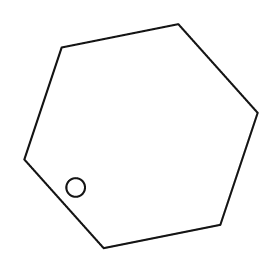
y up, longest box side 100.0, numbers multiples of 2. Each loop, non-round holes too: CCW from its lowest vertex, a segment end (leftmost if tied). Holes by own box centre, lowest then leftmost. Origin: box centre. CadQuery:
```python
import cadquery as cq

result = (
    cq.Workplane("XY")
    .moveTo(-16.0, -48.0)
    .lineTo(34.0, -38.0)
    .lineTo(50.0, 10.0)
    .lineTo(16.0, 48.0)
    .lineTo(-34.0, 38.0)
    .lineTo(-50.0, -10.0)
    .close()
    .moveTo(-28.0, -22.0)
    .circle(4.0)
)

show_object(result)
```